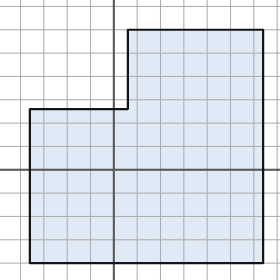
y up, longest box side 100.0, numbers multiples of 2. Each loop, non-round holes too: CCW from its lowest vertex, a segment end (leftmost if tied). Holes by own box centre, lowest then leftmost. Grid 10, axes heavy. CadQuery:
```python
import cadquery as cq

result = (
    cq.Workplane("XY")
    .moveTo(-36.0, -40.0)
    .lineTo(64.0, -40.0)
    .lineTo(64.0, 60.0)
    .lineTo(6.0, 60.0)
    .lineTo(6.0, 26.0)
    .lineTo(-36.0, 26.0)
    .close()
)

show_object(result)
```